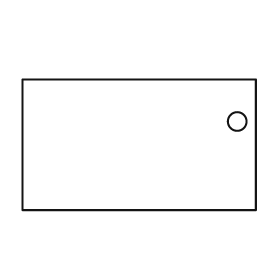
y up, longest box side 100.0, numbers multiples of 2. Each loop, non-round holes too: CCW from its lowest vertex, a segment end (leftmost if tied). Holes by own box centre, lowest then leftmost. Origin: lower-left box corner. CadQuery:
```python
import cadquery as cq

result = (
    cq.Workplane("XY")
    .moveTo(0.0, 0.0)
    .lineTo(100.0, 0.0)
    .lineTo(100.0, 56.0)
    .lineTo(0.0, 56.0)
    .close()
    .moveTo(92.0, 38.0)
    .circle(4.0)
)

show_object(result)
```